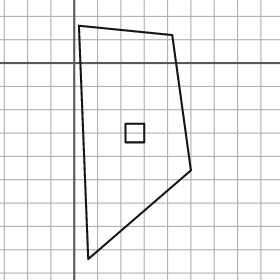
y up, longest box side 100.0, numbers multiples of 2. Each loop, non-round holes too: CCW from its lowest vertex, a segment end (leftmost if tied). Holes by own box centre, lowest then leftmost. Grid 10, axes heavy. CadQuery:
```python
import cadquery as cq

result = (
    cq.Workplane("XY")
    .moveTo(6.0, -84.0)
    .lineTo(50.0, -46.0)
    .lineTo(42.0, 12.0)
    .lineTo(2.0, 16.0)
    .close()
    .moveTo(22.0, -34.0)
    .lineTo(30.0, -34.0)
    .lineTo(30.0, -26.0)
    .lineTo(22.0, -26.0)
    .close()
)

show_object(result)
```